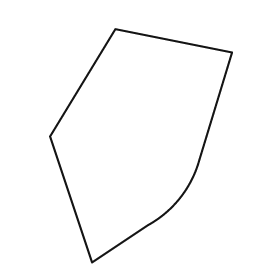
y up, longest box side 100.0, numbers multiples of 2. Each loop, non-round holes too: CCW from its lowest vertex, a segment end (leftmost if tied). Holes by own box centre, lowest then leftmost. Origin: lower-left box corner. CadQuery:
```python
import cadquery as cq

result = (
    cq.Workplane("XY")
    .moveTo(18.0, 0.0)
    .lineTo(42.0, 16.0)
    .threePointArc((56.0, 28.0), (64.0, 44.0))
    .lineTo(78.0, 90.0)
    .lineTo(28.0, 100.0)
    .lineTo(0.0, 54.0)
    .close()
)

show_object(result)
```